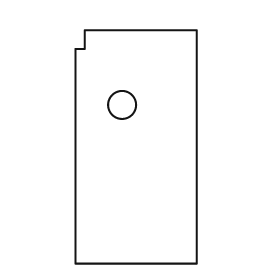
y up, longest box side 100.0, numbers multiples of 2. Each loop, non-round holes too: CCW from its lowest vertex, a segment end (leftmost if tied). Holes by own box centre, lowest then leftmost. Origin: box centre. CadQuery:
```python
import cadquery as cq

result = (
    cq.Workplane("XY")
    .moveTo(-26.0, -50.0)
    .lineTo(26.0, -50.0)
    .lineTo(26.0, 50.0)
    .lineTo(-22.0, 50.0)
    .lineTo(-22.0, 42.0)
    .lineTo(-26.0, 42.0)
    .close()
    .moveTo(-6.0, 18.0)
    .circle(6.0)
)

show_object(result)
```